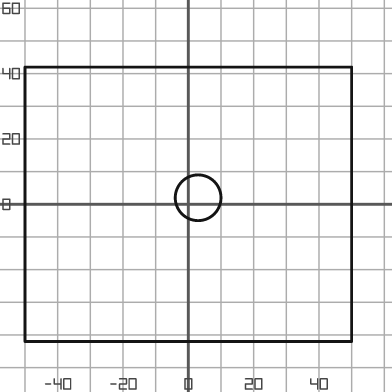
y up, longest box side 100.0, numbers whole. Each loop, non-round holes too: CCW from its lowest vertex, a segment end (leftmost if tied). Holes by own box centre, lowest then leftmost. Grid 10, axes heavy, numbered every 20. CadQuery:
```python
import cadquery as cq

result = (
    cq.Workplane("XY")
    .moveTo(-50.0, -42.0)
    .lineTo(50.0, -42.0)
    .lineTo(50.0, 42.0)
    .lineTo(-50.0, 42.0)
    .close()
    .moveTo(3.0, 2.0)
    .circle(7.0)
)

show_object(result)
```